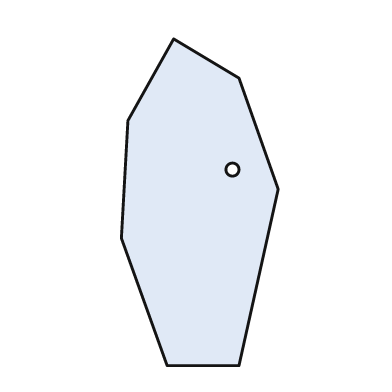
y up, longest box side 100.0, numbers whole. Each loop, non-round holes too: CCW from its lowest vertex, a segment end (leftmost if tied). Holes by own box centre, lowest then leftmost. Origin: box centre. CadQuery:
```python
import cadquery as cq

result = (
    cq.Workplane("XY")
    .moveTo(-10.0, -50.0)
    .lineTo(12.0, -50.0)
    .lineTo(24.0, 4.0)
    .lineTo(12.0, 38.0)
    .lineTo(-8.0, 50.0)
    .lineTo(-22.0, 25.0)
    .lineTo(-24.0, -11.0)
    .close()
    .moveTo(10.0, 10.0)
    .circle(2.0)
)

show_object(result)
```